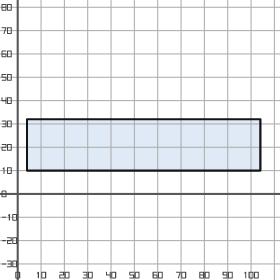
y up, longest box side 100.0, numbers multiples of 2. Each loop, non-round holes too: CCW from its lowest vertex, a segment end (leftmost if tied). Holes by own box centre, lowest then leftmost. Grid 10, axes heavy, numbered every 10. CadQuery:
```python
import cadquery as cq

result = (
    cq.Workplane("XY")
    .moveTo(4.0, 10.0)
    .lineTo(104.0, 10.0)
    .lineTo(104.0, 32.0)
    .lineTo(4.0, 32.0)
    .close()
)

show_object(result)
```